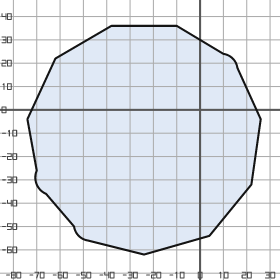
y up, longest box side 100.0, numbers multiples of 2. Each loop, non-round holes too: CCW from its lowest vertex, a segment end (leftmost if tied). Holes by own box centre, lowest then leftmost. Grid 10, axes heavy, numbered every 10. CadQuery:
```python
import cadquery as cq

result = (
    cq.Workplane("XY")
    .moveTo(-24.0, -62.0)
    .lineTo(4.0, -54.0)
    .lineTo(22.0, -32.0)
    .lineTo(26.0, -4.0)
    .lineTo(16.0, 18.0)
    .threePointArc((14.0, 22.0), (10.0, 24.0))
    .lineTo(-10.0, 36.0)
    .lineTo(-38.0, 36.0)
    .lineTo(-62.0, 22.0)
    .lineTo(-74.0, -4.0)
    .lineTo(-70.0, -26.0)
    .threePointArc((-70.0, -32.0), (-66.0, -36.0))
    .lineTo(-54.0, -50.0)
    .threePointArc((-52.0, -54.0), (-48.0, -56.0))
    .close()
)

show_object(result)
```